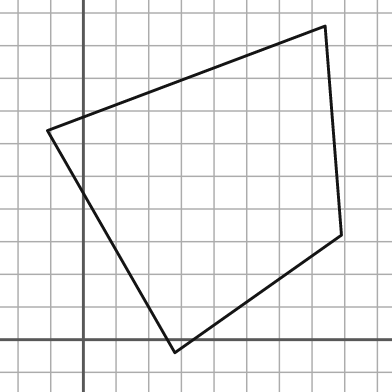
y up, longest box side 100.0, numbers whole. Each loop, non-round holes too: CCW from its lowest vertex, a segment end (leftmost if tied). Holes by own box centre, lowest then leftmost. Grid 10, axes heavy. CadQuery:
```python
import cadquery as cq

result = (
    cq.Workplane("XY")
    .moveTo(28.0, -4.0)
    .lineTo(79.0, 32.0)
    .lineTo(74.0, 96.0)
    .lineTo(-11.0, 64.0)
    .close()
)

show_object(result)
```